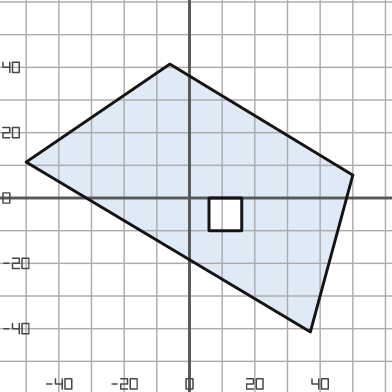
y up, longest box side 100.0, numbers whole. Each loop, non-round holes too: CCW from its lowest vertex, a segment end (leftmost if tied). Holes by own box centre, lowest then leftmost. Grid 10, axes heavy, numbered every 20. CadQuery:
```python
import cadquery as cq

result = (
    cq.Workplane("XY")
    .moveTo(37.0, -41.0)
    .lineTo(50.0, 7.0)
    .lineTo(-6.0, 41.0)
    .lineTo(-50.0, 11.0)
    .close()
    .moveTo(6.0, -10.0)
    .lineTo(16.0, -10.0)
    .lineTo(16.0, 0.0)
    .lineTo(6.0, 0.0)
    .close()
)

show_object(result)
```